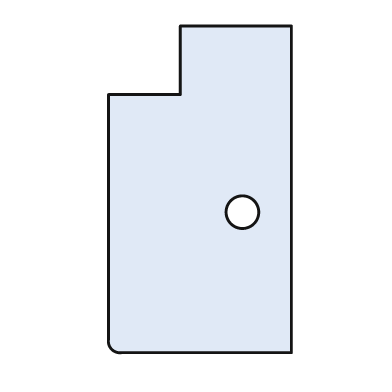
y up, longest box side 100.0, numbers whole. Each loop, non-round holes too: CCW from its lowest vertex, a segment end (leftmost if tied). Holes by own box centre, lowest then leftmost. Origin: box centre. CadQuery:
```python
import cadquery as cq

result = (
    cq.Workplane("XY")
    .moveTo(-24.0, -50.0)
    .lineTo(28.0, -50.0)
    .lineTo(28.0, 50.0)
    .lineTo(-6.0, 50.0)
    .lineTo(-6.0, 29.0)
    .lineTo(-28.0, 29.0)
    .lineTo(-28.0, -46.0)
    .threePointArc((-27.0, -49.0), (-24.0, -50.0))
    .close()
    .moveTo(13.0, -7.0)
    .circle(5.0)
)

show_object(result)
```